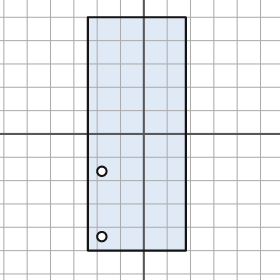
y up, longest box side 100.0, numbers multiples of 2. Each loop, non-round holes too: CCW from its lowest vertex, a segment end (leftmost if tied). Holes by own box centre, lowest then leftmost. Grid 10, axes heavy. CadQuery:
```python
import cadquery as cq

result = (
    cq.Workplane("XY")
    .moveTo(-24.0, -50.0)
    .lineTo(18.0, -50.0)
    .lineTo(18.0, 50.0)
    .lineTo(-24.0, 50.0)
    .close()
    .moveTo(-18.0, -44.0)
    .circle(2.0)
    .moveTo(-18.0, -16.0)
    .circle(2.0)
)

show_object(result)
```